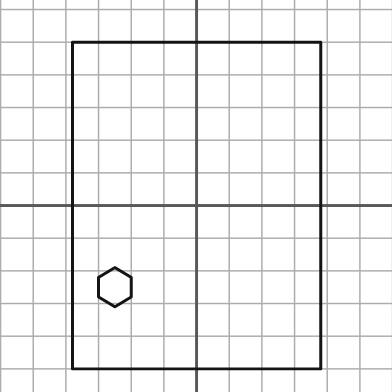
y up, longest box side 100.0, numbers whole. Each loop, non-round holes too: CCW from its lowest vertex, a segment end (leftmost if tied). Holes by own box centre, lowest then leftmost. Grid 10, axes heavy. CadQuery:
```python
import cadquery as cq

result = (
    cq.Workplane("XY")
    .moveTo(-38.0, -50.0)
    .lineTo(38.0, -50.0)
    .lineTo(38.0, 50.0)
    .lineTo(-38.0, 50.0)
    .close()
    .moveTo(-25.0, -31.0)
    .lineTo(-20.0, -28.0)
    .lineTo(-20.0, -22.0)
    .lineTo(-25.0, -19.0)
    .lineTo(-30.0, -22.0)
    .lineTo(-30.0, -28.0)
    .close()
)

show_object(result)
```